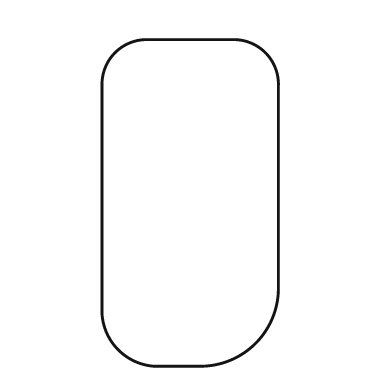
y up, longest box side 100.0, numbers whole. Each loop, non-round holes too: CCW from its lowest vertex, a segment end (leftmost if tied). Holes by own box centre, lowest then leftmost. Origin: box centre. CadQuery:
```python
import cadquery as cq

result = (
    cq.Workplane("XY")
    .moveTo(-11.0, -50.0)
    .lineTo(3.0, -50.0)
    .threePointArc((20.0, -43.0), (27.0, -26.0))
    .lineTo(27.0, 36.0)
    .threePointArc((23.0, 46.0), (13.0, 50.0))
    .lineTo(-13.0, 50.0)
    .threePointArc((-23.0, 46.0), (-27.0, 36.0))
    .lineTo(-27.0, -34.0)
    .threePointArc((-22.0, -45.0), (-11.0, -50.0))
    .close()
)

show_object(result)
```